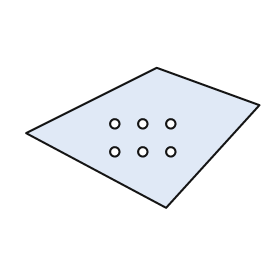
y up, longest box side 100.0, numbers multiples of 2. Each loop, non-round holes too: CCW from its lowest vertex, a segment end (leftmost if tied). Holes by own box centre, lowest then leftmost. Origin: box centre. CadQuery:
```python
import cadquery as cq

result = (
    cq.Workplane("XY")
    .moveTo(10.0, -30.0)
    .lineTo(50.0, 14.0)
    .lineTo(6.0, 30.0)
    .lineTo(-50.0, 2.0)
    .close()
    .moveTo(-12.0, -6.0)
    .circle(2.0)
    .moveTo(0.0, -6.0)
    .circle(2.0)
    .moveTo(12.0, -6.0)
    .circle(2.0)
    .moveTo(-12.0, 6.0)
    .circle(2.0)
    .moveTo(0.0, 6.0)
    .circle(2.0)
    .moveTo(12.0, 6.0)
    .circle(2.0)
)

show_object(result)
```